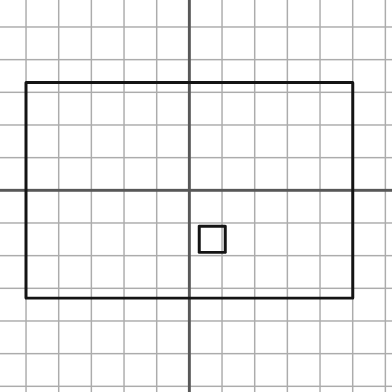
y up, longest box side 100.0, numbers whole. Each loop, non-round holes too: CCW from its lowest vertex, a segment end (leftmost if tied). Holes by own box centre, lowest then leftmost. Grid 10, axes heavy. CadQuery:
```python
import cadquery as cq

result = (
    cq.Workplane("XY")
    .moveTo(-50.0, -33.0)
    .lineTo(50.0, -33.0)
    .lineTo(50.0, 33.0)
    .lineTo(-50.0, 33.0)
    .close()
    .moveTo(3.0, -19.0)
    .lineTo(11.0, -19.0)
    .lineTo(11.0, -11.0)
    .lineTo(3.0, -11.0)
    .close()
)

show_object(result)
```